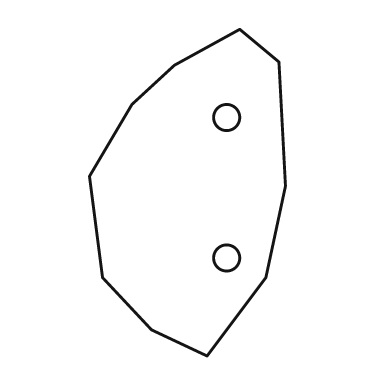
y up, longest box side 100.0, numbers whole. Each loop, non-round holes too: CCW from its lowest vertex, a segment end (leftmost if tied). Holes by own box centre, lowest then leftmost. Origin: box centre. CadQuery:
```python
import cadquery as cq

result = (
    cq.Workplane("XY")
    .moveTo(6.0, -50.0)
    .lineTo(24.0, -26.0)
    .lineTo(30.0, 2.0)
    .lineTo(28.0, 40.0)
    .lineTo(16.0, 50.0)
    .lineTo(-4.0, 39.0)
    .lineTo(-17.0, 27.0)
    .lineTo(-30.0, 5.0)
    .lineTo(-26.0, -26.0)
    .lineTo(-11.0, -42.0)
    .close()
    .moveTo(12.0, -20.0)
    .circle(4.0)
    .moveTo(12.0, 23.0)
    .circle(4.0)
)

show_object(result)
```